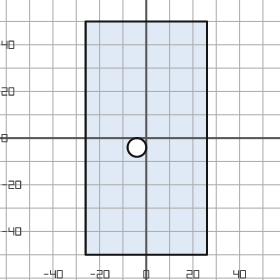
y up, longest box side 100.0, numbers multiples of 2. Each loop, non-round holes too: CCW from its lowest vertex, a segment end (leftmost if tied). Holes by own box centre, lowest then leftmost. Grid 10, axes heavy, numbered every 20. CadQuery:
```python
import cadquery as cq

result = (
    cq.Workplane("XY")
    .moveTo(-26.0, -50.0)
    .lineTo(26.0, -50.0)
    .lineTo(26.0, 50.0)
    .lineTo(-26.0, 50.0)
    .close()
    .moveTo(-4.0, -4.0)
    .circle(4.0)
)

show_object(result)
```